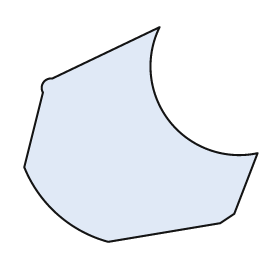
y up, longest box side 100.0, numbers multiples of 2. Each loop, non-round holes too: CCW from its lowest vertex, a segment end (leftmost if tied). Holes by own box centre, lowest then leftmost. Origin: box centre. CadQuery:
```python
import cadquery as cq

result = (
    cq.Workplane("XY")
    .moveTo(-14.0, -46.0)
    .lineTo(34.0, -38.0)
    .lineTo(40.0, -34.0)
    .lineTo(50.0, -8.0)
    .threePointArc((12.0, 6.0), (8.0, 46.0))
    .lineTo(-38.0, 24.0)
    .threePointArc((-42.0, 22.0), (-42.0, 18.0))
    .lineTo(-50.0, -14.0)
    .threePointArc((-36.0, -34.0), (-14.0, -46.0))
    .close()
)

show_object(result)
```